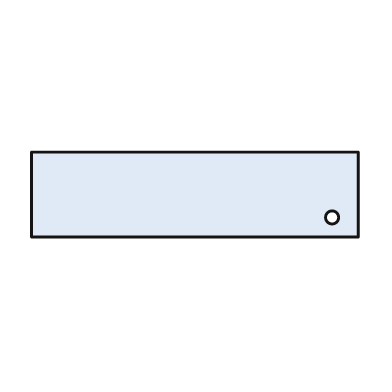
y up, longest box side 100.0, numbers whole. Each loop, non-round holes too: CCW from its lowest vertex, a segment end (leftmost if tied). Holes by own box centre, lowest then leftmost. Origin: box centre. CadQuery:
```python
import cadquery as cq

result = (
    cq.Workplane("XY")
    .moveTo(-50.0, -13.0)
    .lineTo(50.0, -13.0)
    .lineTo(50.0, 13.0)
    .lineTo(-50.0, 13.0)
    .close()
    .moveTo(42.0, -7.0)
    .circle(2.0)
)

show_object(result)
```